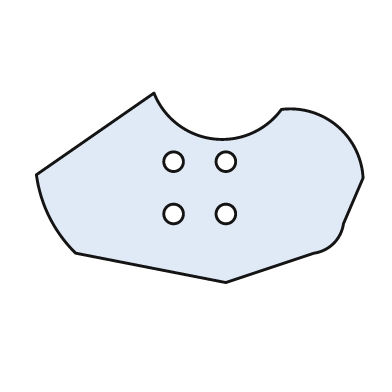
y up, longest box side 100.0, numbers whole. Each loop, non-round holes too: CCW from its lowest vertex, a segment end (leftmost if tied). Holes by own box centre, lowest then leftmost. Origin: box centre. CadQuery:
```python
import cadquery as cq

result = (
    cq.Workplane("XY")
    .moveTo(8.0, -29.0)
    .lineTo(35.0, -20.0)
    .threePointArc((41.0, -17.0), (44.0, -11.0))
    .lineTo(50.0, 3.0)
    .threePointArc((42.0, 19.0), (25.0, 24.0))
    .threePointArc((4.0, 15.0), (-14.0, 29.0))
    .lineTo(-50.0, 4.0)
    .threePointArc((-46.0, -9.0), (-38.0, -20.0))
    .close()
    .moveTo(-8.0, -8.0)
    .circle(3.0)
    .moveTo(8.0, -8.0)
    .circle(3.0)
    .moveTo(-8.0, 8.0)
    .circle(3.0)
    .moveTo(8.0, 8.0)
    .circle(3.0)
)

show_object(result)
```